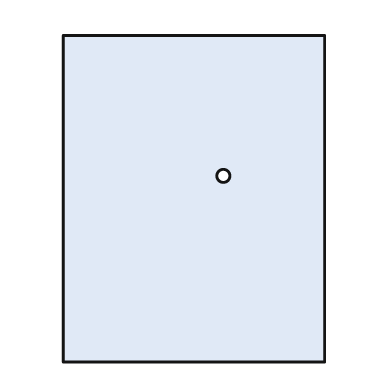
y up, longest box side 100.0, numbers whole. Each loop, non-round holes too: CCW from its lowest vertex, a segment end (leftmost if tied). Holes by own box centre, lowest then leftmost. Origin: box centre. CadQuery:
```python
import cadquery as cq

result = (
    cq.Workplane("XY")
    .moveTo(-40.0, -50.0)
    .lineTo(40.0, -50.0)
    .lineTo(40.0, 50.0)
    .lineTo(-40.0, 50.0)
    .close()
    .moveTo(9.0, 7.0)
    .circle(2.0)
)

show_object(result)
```